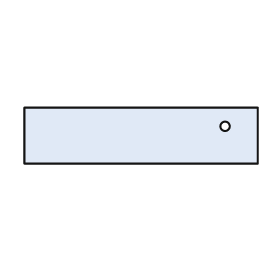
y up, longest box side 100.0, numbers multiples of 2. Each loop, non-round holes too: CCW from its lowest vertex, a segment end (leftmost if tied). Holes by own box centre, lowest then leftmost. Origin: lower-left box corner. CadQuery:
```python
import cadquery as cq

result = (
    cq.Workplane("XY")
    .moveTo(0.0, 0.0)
    .lineTo(100.0, 0.0)
    .lineTo(100.0, 24.0)
    .lineTo(0.0, 24.0)
    .close()
    .moveTo(86.0, 16.0)
    .circle(2.0)
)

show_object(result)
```